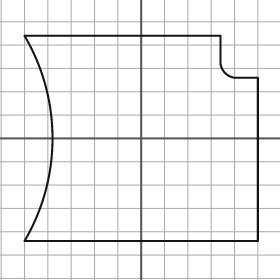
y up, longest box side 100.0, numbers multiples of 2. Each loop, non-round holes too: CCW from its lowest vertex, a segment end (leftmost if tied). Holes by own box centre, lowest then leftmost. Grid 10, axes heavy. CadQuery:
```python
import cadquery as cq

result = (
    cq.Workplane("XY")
    .moveTo(-50.0, -44.0)
    .lineTo(50.0, -44.0)
    .lineTo(50.0, 26.0)
    .lineTo(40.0, 26.0)
    .threePointArc((36.0, 28.0), (34.0, 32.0))
    .lineTo(34.0, 44.0)
    .lineTo(-50.0, 44.0)
    .threePointArc((-38.0, 0.0), (-50.0, -44.0))
    .close()
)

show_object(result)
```